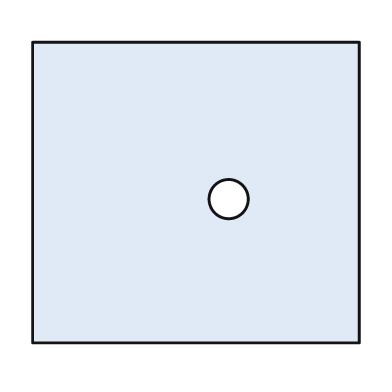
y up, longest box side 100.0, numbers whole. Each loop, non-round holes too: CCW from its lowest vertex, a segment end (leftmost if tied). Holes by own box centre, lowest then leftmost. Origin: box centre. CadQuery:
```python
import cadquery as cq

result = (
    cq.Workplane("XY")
    .moveTo(-50.0, -46.0)
    .lineTo(50.0, -46.0)
    .lineTo(50.0, 46.0)
    .lineTo(-50.0, 46.0)
    .close()
    .moveTo(10.0, -2.0)
    .circle(6.0)
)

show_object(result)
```